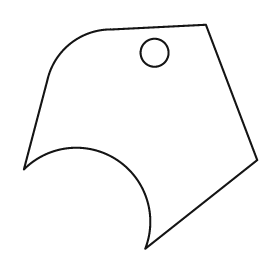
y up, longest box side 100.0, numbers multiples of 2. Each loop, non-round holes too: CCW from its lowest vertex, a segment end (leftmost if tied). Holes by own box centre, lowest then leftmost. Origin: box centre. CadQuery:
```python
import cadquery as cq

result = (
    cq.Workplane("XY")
    .moveTo(2.0, -48.0)
    .lineTo(50.0, -10.0)
    .lineTo(28.0, 48.0)
    .lineTo(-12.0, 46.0)
    .threePointArc((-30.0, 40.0), (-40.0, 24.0))
    .lineTo(-50.0, -14.0)
    .threePointArc((-10.0, -10.0), (2.0, -48.0))
    .close()
    .moveTo(6.0, 36.0)
    .circle(6.0)
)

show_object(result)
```